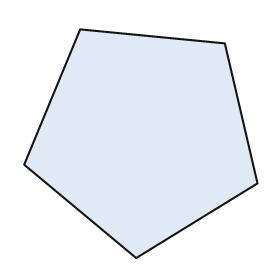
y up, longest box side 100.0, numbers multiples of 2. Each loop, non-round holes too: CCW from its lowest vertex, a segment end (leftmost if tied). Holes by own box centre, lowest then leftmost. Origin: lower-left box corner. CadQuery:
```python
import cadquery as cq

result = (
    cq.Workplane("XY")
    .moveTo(48.0, 0.0)
    .lineTo(100.0, 32.0)
    .lineTo(86.0, 92.0)
    .lineTo(24.0, 98.0)
    .lineTo(0.0, 40.0)
    .close()
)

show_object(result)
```